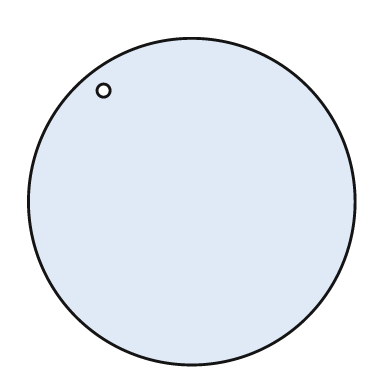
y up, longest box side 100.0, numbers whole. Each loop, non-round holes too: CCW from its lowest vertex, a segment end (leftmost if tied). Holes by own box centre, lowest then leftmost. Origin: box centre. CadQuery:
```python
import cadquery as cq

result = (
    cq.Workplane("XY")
    .moveTo(0.0, 0.0)
    .circle(50.0)
    .moveTo(-27.0, 34.0)
    .circle(2.0)
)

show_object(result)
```